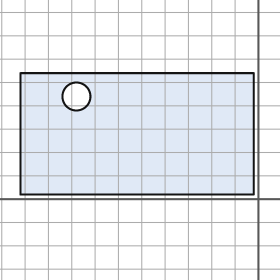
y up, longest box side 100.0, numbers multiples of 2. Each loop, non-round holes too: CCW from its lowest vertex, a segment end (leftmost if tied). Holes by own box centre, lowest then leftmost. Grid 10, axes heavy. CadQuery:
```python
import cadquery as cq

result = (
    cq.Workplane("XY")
    .moveTo(-102.0, 2.0)
    .lineTo(-2.0, 2.0)
    .lineTo(-2.0, 54.0)
    .lineTo(-102.0, 54.0)
    .close()
    .moveTo(-78.0, 44.0)
    .circle(6.0)
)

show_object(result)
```